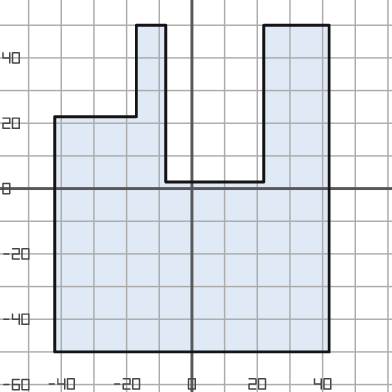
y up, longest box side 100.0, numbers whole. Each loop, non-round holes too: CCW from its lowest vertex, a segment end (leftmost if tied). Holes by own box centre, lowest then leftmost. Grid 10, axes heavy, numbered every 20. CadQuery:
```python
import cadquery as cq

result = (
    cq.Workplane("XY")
    .moveTo(-42.0, -50.0)
    .lineTo(42.0, -50.0)
    .lineTo(42.0, 50.0)
    .lineTo(22.0, 50.0)
    .lineTo(22.0, 2.0)
    .lineTo(-8.0, 2.0)
    .lineTo(-8.0, 50.0)
    .lineTo(-17.0, 50.0)
    .lineTo(-17.0, 22.0)
    .lineTo(-42.0, 22.0)
    .close()
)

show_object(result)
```